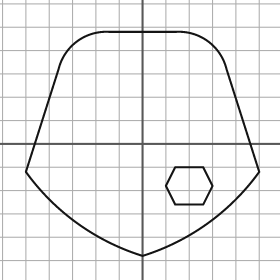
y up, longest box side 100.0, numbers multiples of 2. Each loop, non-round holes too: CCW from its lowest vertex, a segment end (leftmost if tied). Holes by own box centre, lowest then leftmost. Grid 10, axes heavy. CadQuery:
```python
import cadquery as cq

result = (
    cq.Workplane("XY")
    .moveTo(0.0, -48.0)
    .threePointArc((28.0, -34.0), (50.0, -12.0))
    .lineTo(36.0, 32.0)
    .threePointArc((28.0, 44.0), (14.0, 48.0))
    .lineTo(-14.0, 48.0)
    .threePointArc((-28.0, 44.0), (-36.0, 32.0))
    .lineTo(-50.0, -12.0)
    .threePointArc((-28.0, -34.0), (0.0, -48.0))
    .close()
    .moveTo(14.0, -26.0)
    .lineTo(26.0, -26.0)
    .lineTo(30.0, -18.0)
    .lineTo(26.0, -10.0)
    .lineTo(14.0, -10.0)
    .lineTo(10.0, -18.0)
    .close()
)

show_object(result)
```